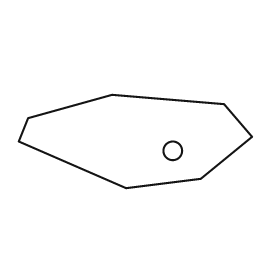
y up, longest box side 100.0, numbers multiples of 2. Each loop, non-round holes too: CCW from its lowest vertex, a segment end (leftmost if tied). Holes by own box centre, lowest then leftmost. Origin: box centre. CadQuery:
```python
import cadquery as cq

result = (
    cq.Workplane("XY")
    .moveTo(-4.0, -20.0)
    .lineTo(28.0, -16.0)
    .lineTo(50.0, 2.0)
    .lineTo(38.0, 16.0)
    .lineTo(-10.0, 20.0)
    .lineTo(-46.0, 10.0)
    .lineTo(-50.0, 0.0)
    .close()
    .moveTo(16.0, -4.0)
    .circle(4.0)
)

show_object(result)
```